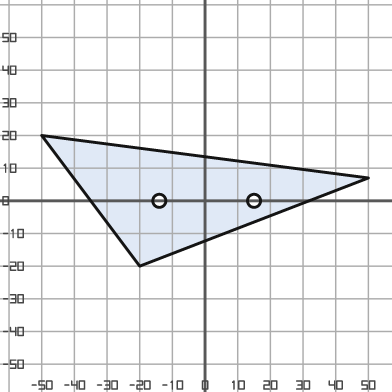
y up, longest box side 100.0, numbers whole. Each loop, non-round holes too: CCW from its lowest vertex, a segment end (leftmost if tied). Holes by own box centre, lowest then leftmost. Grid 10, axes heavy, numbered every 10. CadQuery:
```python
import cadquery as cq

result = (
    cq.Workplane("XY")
    .moveTo(-20.0, -20.0)
    .lineTo(50.0, 7.0)
    .lineTo(-50.0, 20.0)
    .close()
    .moveTo(-14.0, 0.0)
    .circle(2.0)
    .moveTo(15.0, 0.0)
    .circle(2.0)
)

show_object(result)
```